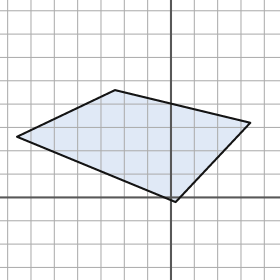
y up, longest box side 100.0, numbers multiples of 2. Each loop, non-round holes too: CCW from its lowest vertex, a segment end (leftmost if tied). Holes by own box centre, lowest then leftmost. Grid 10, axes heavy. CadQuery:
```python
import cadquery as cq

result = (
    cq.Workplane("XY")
    .moveTo(2.0, -2.0)
    .lineTo(34.0, 32.0)
    .lineTo(-24.0, 46.0)
    .lineTo(-66.0, 26.0)
    .close()
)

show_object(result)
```